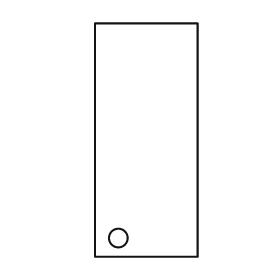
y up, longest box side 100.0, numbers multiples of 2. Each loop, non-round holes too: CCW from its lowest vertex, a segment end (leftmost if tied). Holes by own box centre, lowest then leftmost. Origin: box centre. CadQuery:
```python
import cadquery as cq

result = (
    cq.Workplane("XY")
    .moveTo(-22.0, -50.0)
    .lineTo(22.0, -50.0)
    .lineTo(22.0, 50.0)
    .lineTo(-22.0, 50.0)
    .close()
    .moveTo(-12.0, -42.0)
    .circle(4.0)
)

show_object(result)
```